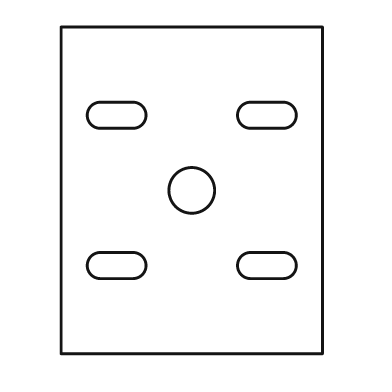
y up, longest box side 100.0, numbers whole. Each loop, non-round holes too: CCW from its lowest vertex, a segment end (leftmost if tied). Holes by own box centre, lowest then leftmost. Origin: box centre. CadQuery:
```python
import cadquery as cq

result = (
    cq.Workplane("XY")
    .moveTo(-40.0, -50.0)
    .lineTo(40.0, -50.0)
    .lineTo(40.0, 50.0)
    .lineTo(-40.0, 50.0)
    .close()
    .moveTo(-28.0, -27.0)
    .lineTo(-18.0, -27.0)
    .threePointArc((-14.0, -23.0), (-18.0, -19.0))
    .lineTo(-28.0, -19.0)
    .threePointArc((-32.0, -23.0), (-28.0, -27.0))
    .close()
    .moveTo(18.0, -27.0)
    .lineTo(28.0, -27.0)
    .threePointArc((32.0, -23.0), (28.0, -19.0))
    .lineTo(18.0, -19.0)
    .threePointArc((14.0, -23.0), (18.0, -27.0))
    .close()
    .moveTo(0.0, 0.0)
    .circle(7.0)
    .moveTo(-28.0, 19.0)
    .lineTo(-18.0, 19.0)
    .threePointArc((-14.0, 23.0), (-18.0, 27.0))
    .lineTo(-28.0, 27.0)
    .threePointArc((-32.0, 23.0), (-28.0, 19.0))
    .close()
    .moveTo(18.0, 19.0)
    .lineTo(28.0, 19.0)
    .threePointArc((32.0, 23.0), (28.0, 27.0))
    .lineTo(18.0, 27.0)
    .threePointArc((14.0, 23.0), (18.0, 19.0))
    .close()
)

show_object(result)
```